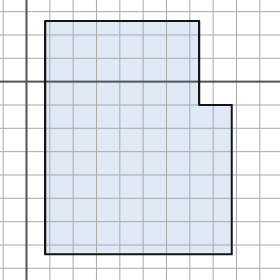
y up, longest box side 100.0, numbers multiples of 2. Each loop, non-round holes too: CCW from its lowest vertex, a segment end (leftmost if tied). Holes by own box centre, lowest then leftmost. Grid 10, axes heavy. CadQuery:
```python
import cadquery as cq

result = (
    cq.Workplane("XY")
    .moveTo(8.0, -74.0)
    .lineTo(88.0, -74.0)
    .lineTo(88.0, -10.0)
    .lineTo(74.0, -10.0)
    .lineTo(74.0, 26.0)
    .lineTo(8.0, 26.0)
    .close()
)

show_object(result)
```